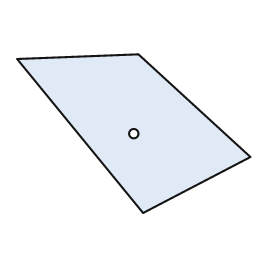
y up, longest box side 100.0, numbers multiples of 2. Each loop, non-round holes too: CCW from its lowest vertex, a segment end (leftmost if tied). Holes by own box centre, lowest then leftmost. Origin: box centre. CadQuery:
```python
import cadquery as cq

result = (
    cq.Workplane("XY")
    .moveTo(4.0, -34.0)
    .lineTo(50.0, -10.0)
    .lineTo(2.0, 34.0)
    .lineTo(-50.0, 32.0)
    .close()
    .moveTo(0.0, 0.0)
    .circle(2.0)
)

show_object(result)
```